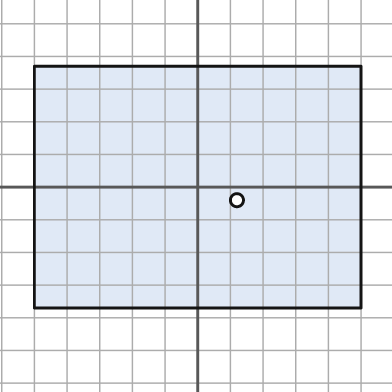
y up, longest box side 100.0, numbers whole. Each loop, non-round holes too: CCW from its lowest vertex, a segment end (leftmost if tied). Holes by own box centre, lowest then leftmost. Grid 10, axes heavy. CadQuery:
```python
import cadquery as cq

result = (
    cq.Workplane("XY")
    .moveTo(-50.0, -37.0)
    .lineTo(50.0, -37.0)
    .lineTo(50.0, 37.0)
    .lineTo(-50.0, 37.0)
    .close()
    .moveTo(12.0, -4.0)
    .circle(2.0)
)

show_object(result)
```